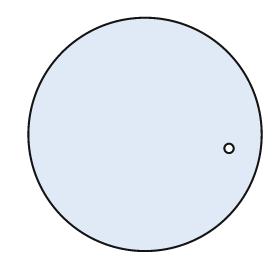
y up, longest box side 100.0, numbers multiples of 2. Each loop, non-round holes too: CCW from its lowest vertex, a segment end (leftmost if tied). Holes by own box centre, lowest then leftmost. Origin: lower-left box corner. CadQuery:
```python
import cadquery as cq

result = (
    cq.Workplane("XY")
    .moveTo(50.0, 50.0)
    .circle(50.0)
    .moveTo(86.0, 44.0)
    .circle(2.0)
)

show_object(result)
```